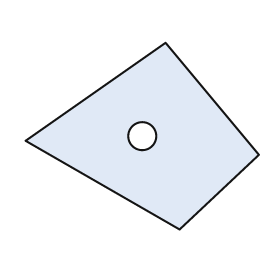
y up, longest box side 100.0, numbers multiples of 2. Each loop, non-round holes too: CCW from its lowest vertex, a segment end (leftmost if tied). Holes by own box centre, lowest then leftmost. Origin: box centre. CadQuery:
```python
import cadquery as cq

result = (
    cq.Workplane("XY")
    .moveTo(16.0, -40.0)
    .lineTo(50.0, -8.0)
    .lineTo(10.0, 40.0)
    .lineTo(-50.0, -2.0)
    .close()
    .moveTo(0.0, 0.0)
    .circle(6.0)
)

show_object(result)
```